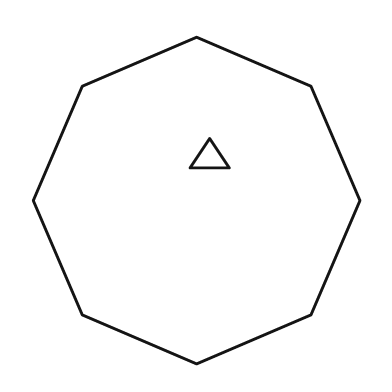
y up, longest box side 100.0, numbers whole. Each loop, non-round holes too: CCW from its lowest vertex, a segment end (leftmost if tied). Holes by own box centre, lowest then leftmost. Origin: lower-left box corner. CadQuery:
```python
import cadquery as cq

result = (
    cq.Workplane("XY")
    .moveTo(50.0, 0.0)
    .lineTo(85.0, 15.0)
    .lineTo(100.0, 50.0)
    .lineTo(85.0, 85.0)
    .lineTo(50.0, 100.0)
    .lineTo(15.0, 85.0)
    .lineTo(0.0, 50.0)
    .lineTo(15.0, 15.0)
    .close()
    .moveTo(48.0, 60.0)
    .lineTo(60.0, 60.0)
    .lineTo(54.0, 69.0)
    .close()
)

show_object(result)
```